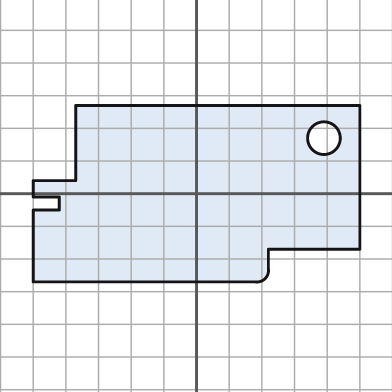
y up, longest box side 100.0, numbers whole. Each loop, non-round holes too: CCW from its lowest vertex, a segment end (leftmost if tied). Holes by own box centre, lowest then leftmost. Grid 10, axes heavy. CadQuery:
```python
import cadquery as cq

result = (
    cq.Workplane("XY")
    .moveTo(-50.0, -27.0)
    .lineTo(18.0, -27.0)
    .threePointArc((21.0, -26.0), (22.0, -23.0))
    .lineTo(22.0, -17.0)
    .lineTo(50.0, -17.0)
    .lineTo(50.0, 27.0)
    .lineTo(-37.0, 27.0)
    .lineTo(-37.0, 4.0)
    .lineTo(-50.0, 4.0)
    .lineTo(-50.0, -1.0)
    .lineTo(-42.0, -1.0)
    .lineTo(-42.0, -5.0)
    .lineTo(-50.0, -5.0)
    .close()
    .moveTo(39.0, 17.0)
    .circle(5.0)
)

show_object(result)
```